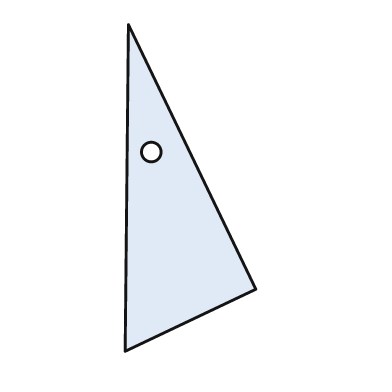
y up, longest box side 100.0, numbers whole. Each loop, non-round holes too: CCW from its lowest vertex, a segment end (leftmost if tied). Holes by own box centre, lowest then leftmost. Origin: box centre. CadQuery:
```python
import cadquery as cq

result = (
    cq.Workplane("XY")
    .moveTo(-20.0, -50.0)
    .lineTo(20.0, -31.0)
    .lineTo(-19.0, 50.0)
    .close()
    .moveTo(-12.0, 11.0)
    .circle(3.0)
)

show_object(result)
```